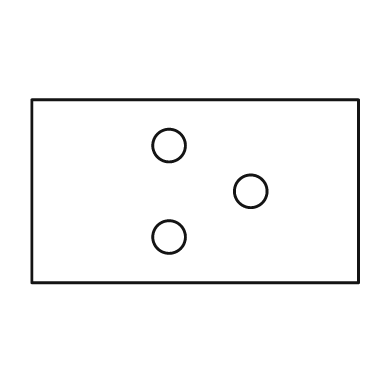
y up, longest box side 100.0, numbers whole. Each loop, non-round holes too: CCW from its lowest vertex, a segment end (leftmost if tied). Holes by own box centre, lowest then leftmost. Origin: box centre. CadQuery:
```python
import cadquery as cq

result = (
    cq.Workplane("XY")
    .moveTo(-50.0, -28.0)
    .lineTo(50.0, -28.0)
    .lineTo(50.0, 28.0)
    .lineTo(-50.0, 28.0)
    .close()
    .moveTo(-8.0, -14.0)
    .circle(5.0)
    .moveTo(17.0, 0.0)
    .circle(5.0)
    .moveTo(-8.0, 14.0)
    .circle(5.0)
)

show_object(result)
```